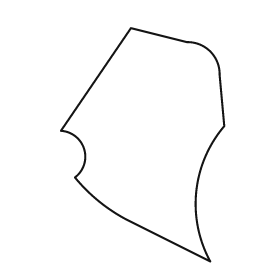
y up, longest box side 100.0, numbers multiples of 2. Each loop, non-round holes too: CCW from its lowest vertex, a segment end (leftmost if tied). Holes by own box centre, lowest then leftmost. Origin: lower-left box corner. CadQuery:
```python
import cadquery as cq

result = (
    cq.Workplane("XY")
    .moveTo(64.0, 0.0)
    .threePointArc((58.0, 30.0), (70.0, 58.0))
    .lineTo(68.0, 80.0)
    .threePointArc((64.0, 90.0), (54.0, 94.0))
    .lineTo(30.0, 100.0)
    .lineTo(0.0, 56.0)
    .threePointArc((10.0, 48.0), (6.0, 36.0))
    .threePointArc((16.0, 26.0), (28.0, 18.0))
    .close()
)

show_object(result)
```